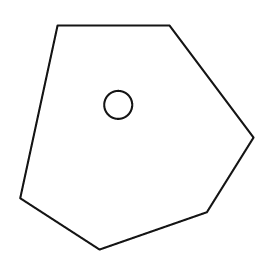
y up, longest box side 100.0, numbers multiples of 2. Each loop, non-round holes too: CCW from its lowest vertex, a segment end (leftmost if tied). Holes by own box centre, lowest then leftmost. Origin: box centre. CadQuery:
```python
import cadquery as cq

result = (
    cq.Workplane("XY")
    .moveTo(-16.0, -48.0)
    .lineTo(30.0, -32.0)
    .lineTo(50.0, 0.0)
    .lineTo(14.0, 48.0)
    .lineTo(-34.0, 48.0)
    .lineTo(-50.0, -26.0)
    .close()
    .moveTo(-8.0, 14.0)
    .circle(6.0)
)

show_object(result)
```